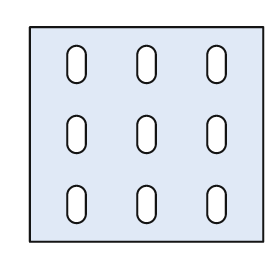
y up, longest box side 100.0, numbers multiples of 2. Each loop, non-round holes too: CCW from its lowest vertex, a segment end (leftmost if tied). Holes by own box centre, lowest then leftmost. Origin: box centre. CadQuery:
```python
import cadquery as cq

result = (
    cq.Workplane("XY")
    .moveTo(-50.0, -46.0)
    .lineTo(50.0, -46.0)
    .lineTo(50.0, 46.0)
    .lineTo(-50.0, 46.0)
    .close()
    .moveTo(-34.0, -34.0)
    .threePointArc((-30.0, -38.0), (-26.0, -34.0))
    .lineTo(-26.0, -26.0)
    .threePointArc((-30.0, -22.0), (-34.0, -26.0))
    .close()
    .moveTo(-4.0, -34.0)
    .threePointArc((0.0, -38.0), (4.0, -34.0))
    .lineTo(4.0, -26.0)
    .threePointArc((0.0, -22.0), (-4.0, -26.0))
    .close()
    .moveTo(26.0, -34.0)
    .threePointArc((30.0, -38.0), (34.0, -34.0))
    .lineTo(34.0, -26.0)
    .threePointArc((30.0, -22.0), (26.0, -26.0))
    .close()
    .moveTo(-34.0, -4.0)
    .threePointArc((-30.0, -8.0), (-26.0, -4.0))
    .lineTo(-26.0, 4.0)
    .threePointArc((-30.0, 8.0), (-34.0, 4.0))
    .close()
    .moveTo(-4.0, -4.0)
    .threePointArc((0.0, -8.0), (4.0, -4.0))
    .lineTo(4.0, 4.0)
    .threePointArc((0.0, 8.0), (-4.0, 4.0))
    .close()
    .moveTo(26.0, -4.0)
    .threePointArc((30.0, -8.0), (34.0, -4.0))
    .lineTo(34.0, 4.0)
    .threePointArc((30.0, 8.0), (26.0, 4.0))
    .close()
    .moveTo(-34.0, 26.0)
    .threePointArc((-30.0, 22.0), (-26.0, 26.0))
    .lineTo(-26.0, 34.0)
    .threePointArc((-30.0, 38.0), (-34.0, 34.0))
    .close()
    .moveTo(-4.0, 26.0)
    .threePointArc((0.0, 22.0), (4.0, 26.0))
    .lineTo(4.0, 34.0)
    .threePointArc((0.0, 38.0), (-4.0, 34.0))
    .close()
    .moveTo(26.0, 26.0)
    .threePointArc((30.0, 22.0), (34.0, 26.0))
    .lineTo(34.0, 34.0)
    .threePointArc((30.0, 38.0), (26.0, 34.0))
    .close()
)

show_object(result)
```